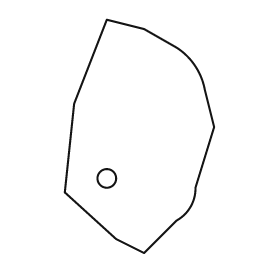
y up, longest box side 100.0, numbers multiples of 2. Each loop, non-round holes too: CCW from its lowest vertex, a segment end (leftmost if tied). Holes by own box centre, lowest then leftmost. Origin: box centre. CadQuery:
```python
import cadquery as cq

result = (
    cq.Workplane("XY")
    .moveTo(2.0, -50.0)
    .lineTo(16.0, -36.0)
    .threePointArc((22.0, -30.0), (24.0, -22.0))
    .lineTo(32.0, 4.0)
    .lineTo(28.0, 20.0)
    .threePointArc((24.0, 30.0), (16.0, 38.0))
    .lineTo(2.0, 46.0)
    .lineTo(-14.0, 50.0)
    .lineTo(-28.0, 14.0)
    .lineTo(-32.0, -24.0)
    .lineTo(-10.0, -44.0)
    .close()
    .moveTo(-14.0, -18.0)
    .circle(4.0)
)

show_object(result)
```